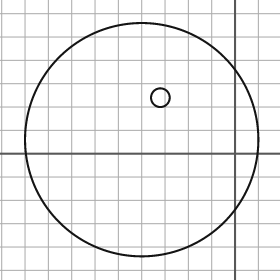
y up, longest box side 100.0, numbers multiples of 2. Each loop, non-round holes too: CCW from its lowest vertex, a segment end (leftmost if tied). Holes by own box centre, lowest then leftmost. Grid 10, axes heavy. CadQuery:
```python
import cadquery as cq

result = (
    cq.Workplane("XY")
    .moveTo(-40.0, 6.0)
    .circle(50.0)
    .moveTo(-32.0, 24.0)
    .circle(4.0)
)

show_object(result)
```